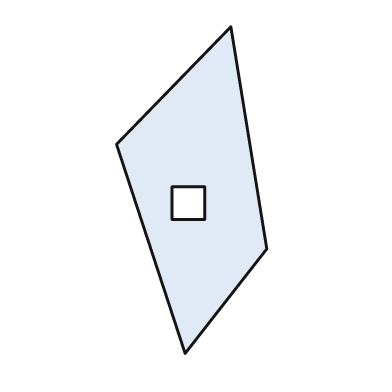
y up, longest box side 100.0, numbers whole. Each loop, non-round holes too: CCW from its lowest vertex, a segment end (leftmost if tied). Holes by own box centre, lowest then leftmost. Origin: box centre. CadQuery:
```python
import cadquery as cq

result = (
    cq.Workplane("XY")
    .moveTo(-2.0, -50.0)
    .lineTo(23.0, -18.0)
    .lineTo(12.0, 50.0)
    .lineTo(-23.0, 14.0)
    .close()
    .moveTo(-6.0, -9.0)
    .lineTo(4.0, -9.0)
    .lineTo(4.0, 1.0)
    .lineTo(-6.0, 1.0)
    .close()
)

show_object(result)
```